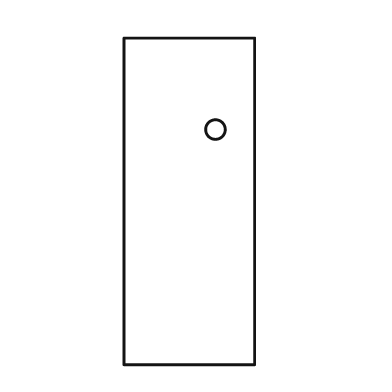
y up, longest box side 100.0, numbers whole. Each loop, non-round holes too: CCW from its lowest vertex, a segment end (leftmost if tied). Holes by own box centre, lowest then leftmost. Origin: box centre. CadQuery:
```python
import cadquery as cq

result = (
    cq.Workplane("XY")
    .moveTo(-20.0, -50.0)
    .lineTo(20.0, -50.0)
    .lineTo(20.0, 50.0)
    .lineTo(-20.0, 50.0)
    .close()
    .moveTo(8.0, 22.0)
    .circle(3.0)
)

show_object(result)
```